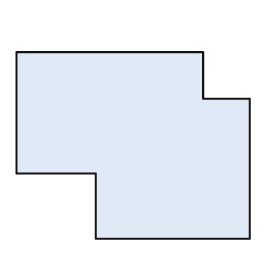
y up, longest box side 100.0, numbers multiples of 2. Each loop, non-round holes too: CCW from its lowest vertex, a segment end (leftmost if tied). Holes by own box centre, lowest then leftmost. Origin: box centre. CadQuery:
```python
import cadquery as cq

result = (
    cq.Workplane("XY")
    .moveTo(-16.0, -40.0)
    .lineTo(50.0, -40.0)
    .lineTo(50.0, 20.0)
    .lineTo(30.0, 20.0)
    .lineTo(30.0, 40.0)
    .lineTo(-50.0, 40.0)
    .lineTo(-50.0, -12.0)
    .lineTo(-16.0, -12.0)
    .close()
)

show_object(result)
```